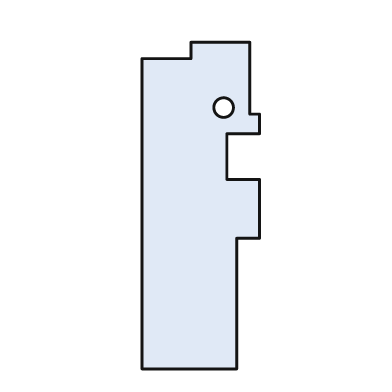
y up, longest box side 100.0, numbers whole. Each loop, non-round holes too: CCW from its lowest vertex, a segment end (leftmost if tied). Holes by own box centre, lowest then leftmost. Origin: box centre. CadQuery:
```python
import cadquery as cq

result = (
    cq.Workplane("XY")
    .moveTo(-18.0, -50.0)
    .lineTo(11.0, -50.0)
    .lineTo(11.0, -10.0)
    .lineTo(18.0, -10.0)
    .lineTo(18.0, 8.0)
    .lineTo(8.0, 8.0)
    .lineTo(8.0, 22.0)
    .lineTo(18.0, 22.0)
    .lineTo(18.0, 28.0)
    .lineTo(15.0, 28.0)
    .lineTo(15.0, 50.0)
    .lineTo(-3.0, 50.0)
    .lineTo(-3.0, 45.0)
    .lineTo(-18.0, 45.0)
    .close()
    .moveTo(7.0, 30.0)
    .circle(3.0)
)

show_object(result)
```